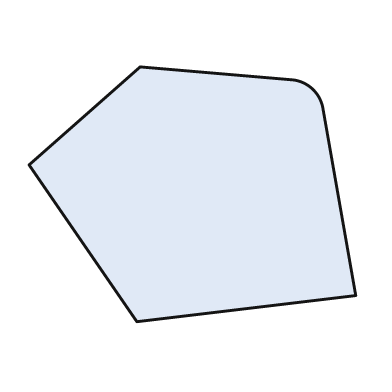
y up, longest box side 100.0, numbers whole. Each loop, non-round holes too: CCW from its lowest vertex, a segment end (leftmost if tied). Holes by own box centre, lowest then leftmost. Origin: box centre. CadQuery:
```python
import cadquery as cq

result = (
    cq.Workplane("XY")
    .moveTo(-17.0, -39.0)
    .lineTo(50.0, -31.0)
    .lineTo(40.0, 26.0)
    .threePointArc((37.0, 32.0), (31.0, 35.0))
    .lineTo(-16.0, 39.0)
    .lineTo(-50.0, 9.0)
    .close()
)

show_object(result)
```